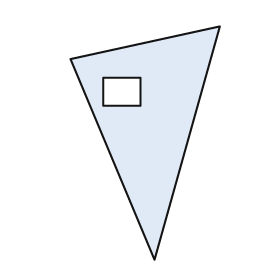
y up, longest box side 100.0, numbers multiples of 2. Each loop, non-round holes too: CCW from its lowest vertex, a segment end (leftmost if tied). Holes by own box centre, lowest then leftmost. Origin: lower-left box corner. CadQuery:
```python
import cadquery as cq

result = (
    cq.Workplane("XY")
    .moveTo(36.0, 0.0)
    .lineTo(64.0, 100.0)
    .lineTo(0.0, 86.0)
    .close()
    .moveTo(14.0, 66.0)
    .lineTo(30.0, 66.0)
    .lineTo(30.0, 78.0)
    .lineTo(14.0, 78.0)
    .close()
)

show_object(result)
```